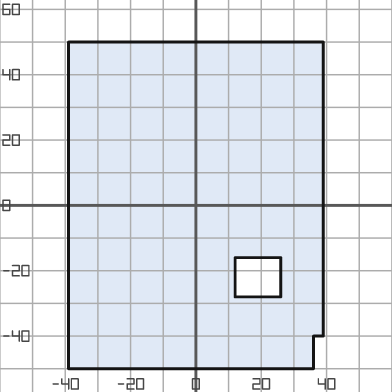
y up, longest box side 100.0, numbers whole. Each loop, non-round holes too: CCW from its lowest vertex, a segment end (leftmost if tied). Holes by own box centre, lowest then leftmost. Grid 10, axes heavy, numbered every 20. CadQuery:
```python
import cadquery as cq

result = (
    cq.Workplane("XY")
    .moveTo(-39.0, -50.0)
    .lineTo(36.0, -50.0)
    .lineTo(36.0, -40.0)
    .lineTo(39.0, -40.0)
    .lineTo(39.0, 50.0)
    .lineTo(-39.0, 50.0)
    .close()
    .moveTo(12.0, -28.0)
    .lineTo(26.0, -28.0)
    .lineTo(26.0, -16.0)
    .lineTo(12.0, -16.0)
    .close()
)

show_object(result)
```